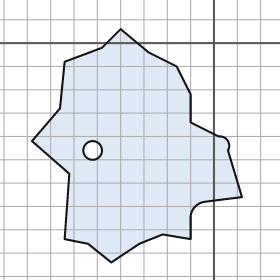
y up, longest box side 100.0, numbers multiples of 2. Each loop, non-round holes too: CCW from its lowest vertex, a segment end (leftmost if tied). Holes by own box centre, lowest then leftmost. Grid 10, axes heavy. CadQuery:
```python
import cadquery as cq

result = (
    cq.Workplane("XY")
    .moveTo(-44.0, -94.0)
    .lineTo(-32.0, -86.0)
    .lineTo(-22.0, -82.0)
    .lineTo(-10.0, -84.0)
    .lineTo(-10.0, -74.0)
    .threePointArc((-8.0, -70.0), (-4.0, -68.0))
    .lineTo(12.0, -66.0)
    .lineTo(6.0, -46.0)
    .threePointArc((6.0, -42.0), (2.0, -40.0))
    .lineTo(-10.0, -34.0)
    .lineTo(-10.0, -22.0)
    .lineTo(-16.0, -10.0)
    .lineTo(-28.0, -4.0)
    .lineTo(-40.0, 6.0)
    .lineTo(-48.0, -2.0)
    .lineTo(-64.0, -8.0)
    .lineTo(-66.0, -28.0)
    .lineTo(-78.0, -42.0)
    .lineTo(-62.0, -56.0)
    .lineTo(-64.0, -84.0)
    .lineTo(-54.0, -86.0)
    .close()
    .moveTo(-52.0, -46.0)
    .circle(4.0)
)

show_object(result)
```